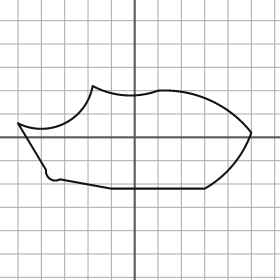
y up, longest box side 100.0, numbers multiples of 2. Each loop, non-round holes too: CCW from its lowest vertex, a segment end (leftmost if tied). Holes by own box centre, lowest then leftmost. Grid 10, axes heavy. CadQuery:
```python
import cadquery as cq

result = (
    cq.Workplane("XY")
    .moveTo(-10.0, -22.0)
    .lineTo(30.0, -22.0)
    .threePointArc((42.0, -12.0), (50.0, 2.0))
    .threePointArc((32.0, 16.0), (10.0, 20.0))
    .threePointArc((-4.0, 18.0), (-18.0, 22.0))
    .threePointArc((-30.0, 6.0), (-50.0, 6.0))
    .lineTo(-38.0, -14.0)
    .threePointArc((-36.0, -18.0), (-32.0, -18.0))
    .close()
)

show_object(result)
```